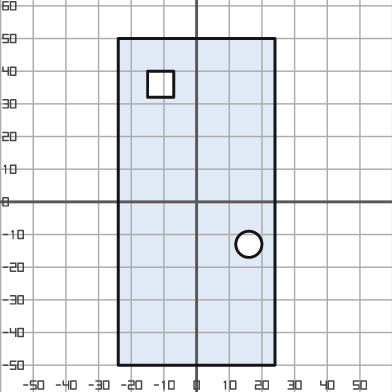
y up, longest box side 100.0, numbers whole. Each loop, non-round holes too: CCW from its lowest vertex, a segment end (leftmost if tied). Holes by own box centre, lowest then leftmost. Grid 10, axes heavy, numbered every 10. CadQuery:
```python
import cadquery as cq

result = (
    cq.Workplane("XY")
    .moveTo(-24.0, -50.0)
    .lineTo(24.0, -50.0)
    .lineTo(24.0, 50.0)
    .lineTo(-24.0, 50.0)
    .close()
    .moveTo(16.0, -13.0)
    .circle(4.0)
    .moveTo(-15.0, 32.0)
    .lineTo(-7.0, 32.0)
    .lineTo(-7.0, 40.0)
    .lineTo(-15.0, 40.0)
    .close()
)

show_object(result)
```